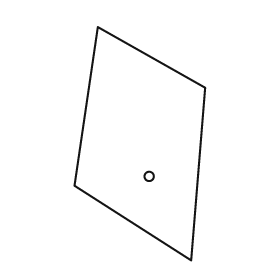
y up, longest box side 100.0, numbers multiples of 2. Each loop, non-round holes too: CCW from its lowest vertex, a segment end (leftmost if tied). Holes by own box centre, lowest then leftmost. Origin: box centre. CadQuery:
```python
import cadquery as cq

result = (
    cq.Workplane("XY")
    .moveTo(22.0, -50.0)
    .lineTo(28.0, 24.0)
    .lineTo(-18.0, 50.0)
    .lineTo(-28.0, -18.0)
    .close()
    .moveTo(4.0, -14.0)
    .circle(2.0)
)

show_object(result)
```